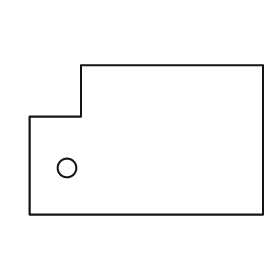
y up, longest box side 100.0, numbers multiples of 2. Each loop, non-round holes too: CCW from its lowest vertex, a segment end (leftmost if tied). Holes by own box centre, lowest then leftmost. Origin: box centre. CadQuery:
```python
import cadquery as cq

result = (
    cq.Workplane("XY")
    .moveTo(-50.0, -32.0)
    .lineTo(50.0, -32.0)
    .lineTo(50.0, 32.0)
    .lineTo(-28.0, 32.0)
    .lineTo(-28.0, 10.0)
    .lineTo(-50.0, 10.0)
    .close()
    .moveTo(-34.0, -12.0)
    .circle(4.0)
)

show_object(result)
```